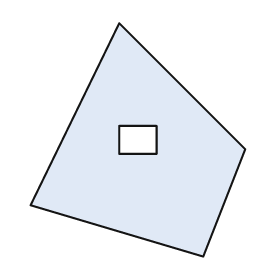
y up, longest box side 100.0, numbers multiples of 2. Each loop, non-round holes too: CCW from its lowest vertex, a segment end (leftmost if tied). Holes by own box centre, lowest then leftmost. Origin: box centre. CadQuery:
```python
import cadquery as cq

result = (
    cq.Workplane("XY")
    .moveTo(28.0, -50.0)
    .lineTo(46.0, -4.0)
    .lineTo(-8.0, 50.0)
    .lineTo(-46.0, -28.0)
    .close()
    .moveTo(-8.0, -6.0)
    .lineTo(8.0, -6.0)
    .lineTo(8.0, 6.0)
    .lineTo(-8.0, 6.0)
    .close()
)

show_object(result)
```